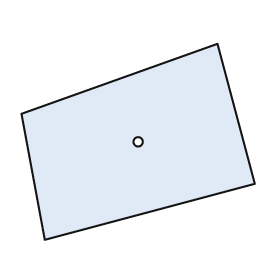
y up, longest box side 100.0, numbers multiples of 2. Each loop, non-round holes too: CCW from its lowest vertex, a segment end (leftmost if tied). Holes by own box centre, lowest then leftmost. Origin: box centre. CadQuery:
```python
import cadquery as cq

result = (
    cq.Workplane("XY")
    .moveTo(-40.0, -42.0)
    .lineTo(50.0, -18.0)
    .lineTo(34.0, 42.0)
    .lineTo(-50.0, 12.0)
    .close()
    .moveTo(0.0, 0.0)
    .circle(2.0)
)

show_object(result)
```